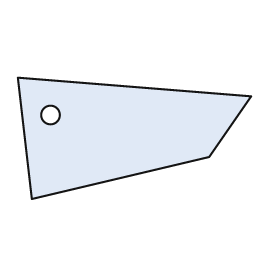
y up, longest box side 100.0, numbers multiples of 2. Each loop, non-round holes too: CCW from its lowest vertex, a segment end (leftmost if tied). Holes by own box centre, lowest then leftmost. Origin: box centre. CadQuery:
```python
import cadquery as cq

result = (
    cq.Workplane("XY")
    .moveTo(-44.0, -26.0)
    .lineTo(32.0, -8.0)
    .lineTo(50.0, 18.0)
    .lineTo(-50.0, 26.0)
    .close()
    .moveTo(-36.0, 10.0)
    .circle(4.0)
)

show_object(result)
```